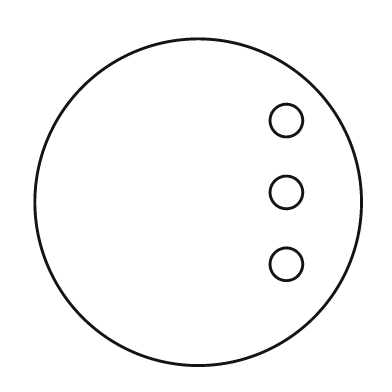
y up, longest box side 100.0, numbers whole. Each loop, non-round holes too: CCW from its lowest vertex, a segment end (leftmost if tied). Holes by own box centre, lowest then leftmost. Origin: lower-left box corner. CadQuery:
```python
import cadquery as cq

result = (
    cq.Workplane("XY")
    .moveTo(50.0, 50.0)
    .circle(50.0)
    .moveTo(77.0, 31.0)
    .circle(5.0)
    .moveTo(77.0, 53.0)
    .circle(5.0)
    .moveTo(77.0, 75.0)
    .circle(5.0)
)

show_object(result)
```